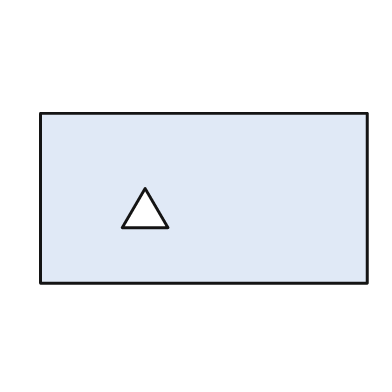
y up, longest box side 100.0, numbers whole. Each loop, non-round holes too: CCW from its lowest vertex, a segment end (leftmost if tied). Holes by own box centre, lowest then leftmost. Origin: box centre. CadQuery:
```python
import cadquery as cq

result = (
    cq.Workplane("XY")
    .moveTo(-50.0, -26.0)
    .lineTo(50.0, -26.0)
    .lineTo(50.0, 26.0)
    .lineTo(-50.0, 26.0)
    .close()
    .moveTo(-25.0, -9.0)
    .lineTo(-11.0, -9.0)
    .lineTo(-18.0, 3.0)
    .close()
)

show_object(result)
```